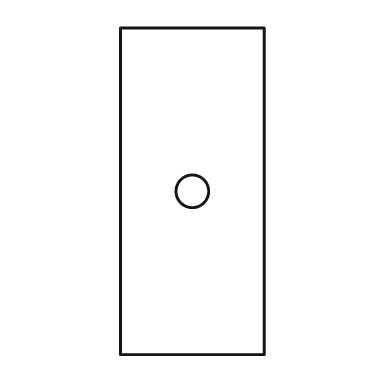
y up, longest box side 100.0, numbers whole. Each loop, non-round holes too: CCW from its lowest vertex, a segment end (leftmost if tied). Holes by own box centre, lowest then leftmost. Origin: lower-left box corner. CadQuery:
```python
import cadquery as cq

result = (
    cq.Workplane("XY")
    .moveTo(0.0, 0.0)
    .lineTo(44.0, 0.0)
    .lineTo(44.0, 100.0)
    .lineTo(0.0, 100.0)
    .close()
    .moveTo(22.0, 50.0)
    .circle(5.0)
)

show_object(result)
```